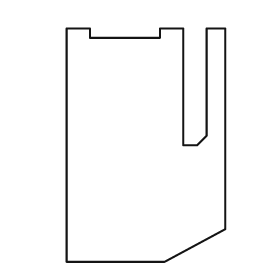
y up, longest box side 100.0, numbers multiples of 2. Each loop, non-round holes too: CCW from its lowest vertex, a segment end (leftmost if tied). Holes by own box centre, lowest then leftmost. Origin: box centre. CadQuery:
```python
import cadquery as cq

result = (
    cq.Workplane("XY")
    .moveTo(-34.0, -50.0)
    .lineTo(8.0, -50.0)
    .lineTo(34.0, -36.0)
    .lineTo(34.0, 50.0)
    .lineTo(26.0, 50.0)
    .lineTo(26.0, 4.0)
    .lineTo(22.0, 0.0)
    .lineTo(16.0, 0.0)
    .lineTo(16.0, 50.0)
    .lineTo(6.0, 50.0)
    .lineTo(6.0, 46.0)
    .lineTo(-24.0, 46.0)
    .lineTo(-24.0, 50.0)
    .lineTo(-34.0, 50.0)
    .close()
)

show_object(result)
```